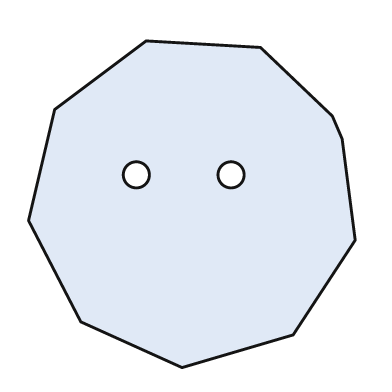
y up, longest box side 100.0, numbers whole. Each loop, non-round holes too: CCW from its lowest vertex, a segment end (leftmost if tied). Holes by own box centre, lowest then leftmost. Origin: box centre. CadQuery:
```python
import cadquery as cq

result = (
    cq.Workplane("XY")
    .moveTo(-3.0, -50.0)
    .lineTo(31.0, -40.0)
    .lineTo(50.0, -11.0)
    .lineTo(46.0, 20.0)
    .lineTo(43.0, 27.0)
    .lineTo(21.0, 48.0)
    .lineTo(-14.0, 50.0)
    .lineTo(-42.0, 29.0)
    .lineTo(-50.0, -5.0)
    .lineTo(-34.0, -36.0)
    .close()
    .moveTo(-17.0, 9.0)
    .circle(4.0)
    .moveTo(12.0, 9.0)
    .circle(4.0)
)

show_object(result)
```